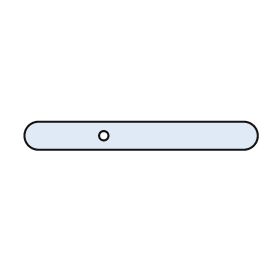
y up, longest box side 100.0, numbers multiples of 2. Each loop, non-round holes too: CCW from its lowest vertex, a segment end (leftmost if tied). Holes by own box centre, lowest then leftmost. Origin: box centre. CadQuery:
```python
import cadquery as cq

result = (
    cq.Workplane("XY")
    .moveTo(-44.0, -6.0)
    .lineTo(44.0, -6.0)
    .threePointArc((50.0, 0.0), (44.0, 6.0))
    .lineTo(-44.0, 6.0)
    .threePointArc((-50.0, 0.0), (-44.0, -6.0))
    .close()
    .moveTo(-16.0, 0.0)
    .circle(2.0)
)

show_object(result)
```